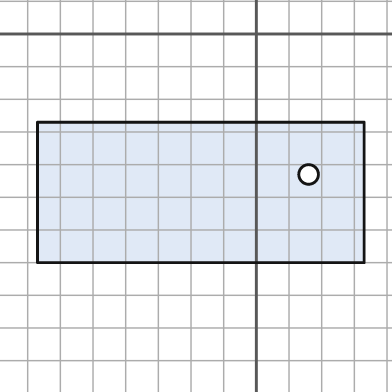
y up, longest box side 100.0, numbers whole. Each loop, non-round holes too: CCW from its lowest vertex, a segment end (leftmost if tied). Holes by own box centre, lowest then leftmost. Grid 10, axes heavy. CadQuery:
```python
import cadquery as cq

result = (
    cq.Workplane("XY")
    .moveTo(-67.0, -70.0)
    .lineTo(33.0, -70.0)
    .lineTo(33.0, -27.0)
    .lineTo(-67.0, -27.0)
    .close()
    .moveTo(16.0, -43.0)
    .circle(3.0)
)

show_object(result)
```